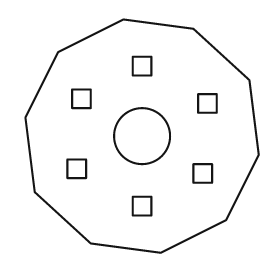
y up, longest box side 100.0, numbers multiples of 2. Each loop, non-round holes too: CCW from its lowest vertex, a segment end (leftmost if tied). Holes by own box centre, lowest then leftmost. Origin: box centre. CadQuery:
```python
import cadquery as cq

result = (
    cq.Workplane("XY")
    .moveTo(8.0, -50.0)
    .lineTo(36.0, -36.0)
    .lineTo(50.0, -8.0)
    .lineTo(46.0, 24.0)
    .lineTo(22.0, 46.0)
    .lineTo(-8.0, 50.0)
    .lineTo(-36.0, 36.0)
    .lineTo(-50.0, 8.0)
    .lineTo(-46.0, -24.0)
    .lineTo(-22.0, -46.0)
    .close()
    .moveTo(-4.0, -34.0)
    .lineTo(4.0, -34.0)
    .lineTo(4.0, -26.0)
    .lineTo(-4.0, -26.0)
    .close()
    .moveTo(22.0, -20.0)
    .lineTo(30.0, -20.0)
    .lineTo(30.0, -12.0)
    .lineTo(22.0, -12.0)
    .close()
    .moveTo(-32.0, -18.0)
    .lineTo(-24.0, -18.0)
    .lineTo(-24.0, -10.0)
    .lineTo(-32.0, -10.0)
    .close()
    .moveTo(0.0, 0.0)
    .circle(12.0)
    .moveTo(24.0, 10.0)
    .lineTo(32.0, 10.0)
    .lineTo(32.0, 18.0)
    .lineTo(24.0, 18.0)
    .close()
    .moveTo(-30.0, 12.0)
    .lineTo(-22.0, 12.0)
    .lineTo(-22.0, 20.0)
    .lineTo(-30.0, 20.0)
    .close()
    .moveTo(-4.0, 26.0)
    .lineTo(4.0, 26.0)
    .lineTo(4.0, 34.0)
    .lineTo(-4.0, 34.0)
    .close()
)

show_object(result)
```